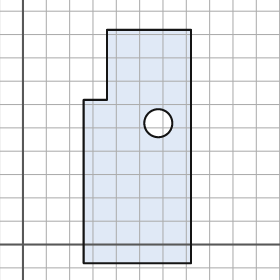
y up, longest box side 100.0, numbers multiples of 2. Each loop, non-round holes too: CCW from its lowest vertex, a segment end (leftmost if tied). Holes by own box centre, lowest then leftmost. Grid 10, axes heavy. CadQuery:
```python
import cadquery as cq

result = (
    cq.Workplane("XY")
    .moveTo(26.0, -8.0)
    .lineTo(72.0, -8.0)
    .lineTo(72.0, 92.0)
    .lineTo(36.0, 92.0)
    .lineTo(36.0, 62.0)
    .lineTo(26.0, 62.0)
    .close()
    .moveTo(58.0, 52.0)
    .circle(6.0)
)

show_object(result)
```